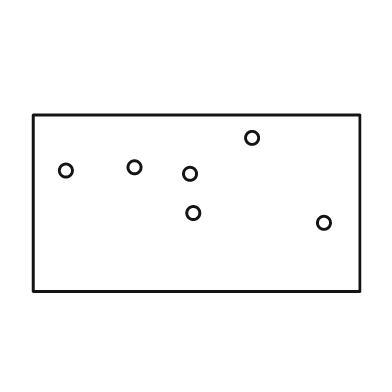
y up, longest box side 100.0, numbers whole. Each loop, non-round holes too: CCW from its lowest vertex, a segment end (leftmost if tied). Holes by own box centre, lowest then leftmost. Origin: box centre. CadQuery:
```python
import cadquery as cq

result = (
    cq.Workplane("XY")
    .moveTo(-50.0, -27.0)
    .lineTo(50.0, -27.0)
    .lineTo(50.0, 27.0)
    .lineTo(-50.0, 27.0)
    .close()
    .moveTo(39.0, -6.0)
    .circle(2.0)
    .moveTo(-1.0, -3.0)
    .circle(2.0)
    .moveTo(-2.0, 9.0)
    .circle(2.0)
    .moveTo(-40.0, 10.0)
    .circle(2.0)
    .moveTo(-19.0, 11.0)
    .circle(2.0)
    .moveTo(17.0, 20.0)
    .circle(2.0)
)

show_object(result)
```